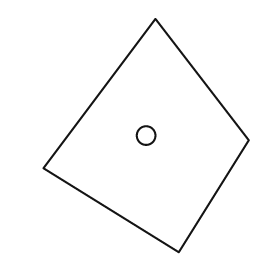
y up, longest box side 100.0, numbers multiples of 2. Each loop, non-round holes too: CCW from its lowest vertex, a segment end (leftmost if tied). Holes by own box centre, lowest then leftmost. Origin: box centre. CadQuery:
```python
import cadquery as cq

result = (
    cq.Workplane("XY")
    .moveTo(14.0, -50.0)
    .lineTo(44.0, -2.0)
    .lineTo(4.0, 50.0)
    .lineTo(-44.0, -14.0)
    .close()
    .moveTo(0.0, 0.0)
    .circle(4.0)
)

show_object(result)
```